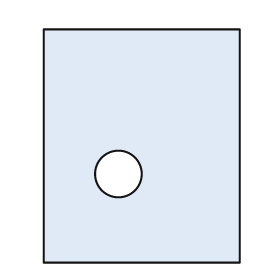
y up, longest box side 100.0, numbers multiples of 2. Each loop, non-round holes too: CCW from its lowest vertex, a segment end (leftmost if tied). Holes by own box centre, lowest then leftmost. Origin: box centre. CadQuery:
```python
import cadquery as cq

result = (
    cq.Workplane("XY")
    .moveTo(-42.0, -50.0)
    .lineTo(42.0, -50.0)
    .lineTo(42.0, 50.0)
    .lineTo(-42.0, 50.0)
    .close()
    .moveTo(-10.0, -12.0)
    .circle(10.0)
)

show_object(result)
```